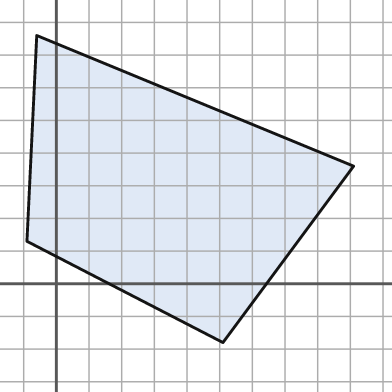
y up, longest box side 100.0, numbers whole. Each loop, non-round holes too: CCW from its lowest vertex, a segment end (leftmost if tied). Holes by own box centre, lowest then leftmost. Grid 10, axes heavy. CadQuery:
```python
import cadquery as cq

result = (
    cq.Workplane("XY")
    .moveTo(51.0, -18.0)
    .lineTo(91.0, 36.0)
    .lineTo(-6.0, 76.0)
    .lineTo(-9.0, 13.0)
    .close()
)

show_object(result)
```